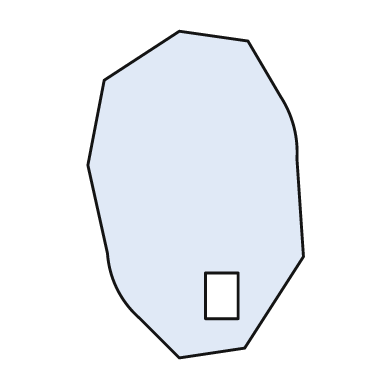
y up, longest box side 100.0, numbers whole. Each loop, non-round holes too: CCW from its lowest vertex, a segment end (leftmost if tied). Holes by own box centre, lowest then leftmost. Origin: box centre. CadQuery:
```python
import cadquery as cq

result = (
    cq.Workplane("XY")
    .moveTo(-5.0, -50.0)
    .lineTo(15.0, -47.0)
    .lineTo(33.0, -19.0)
    .lineTo(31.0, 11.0)
    .threePointArc((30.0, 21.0), (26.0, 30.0))
    .lineTo(16.0, 47.0)
    .lineTo(-5.0, 50.0)
    .lineTo(-28.0, 35.0)
    .lineTo(-33.0, 9.0)
    .lineTo(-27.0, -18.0)
    .threePointArc((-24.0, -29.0), (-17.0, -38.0))
    .close()
    .moveTo(3.0, -38.0)
    .lineTo(13.0, -38.0)
    .lineTo(13.0, -24.0)
    .lineTo(3.0, -24.0)
    .close()
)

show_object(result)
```